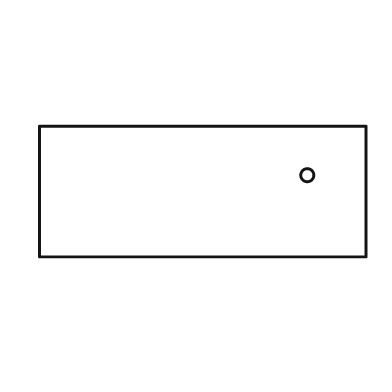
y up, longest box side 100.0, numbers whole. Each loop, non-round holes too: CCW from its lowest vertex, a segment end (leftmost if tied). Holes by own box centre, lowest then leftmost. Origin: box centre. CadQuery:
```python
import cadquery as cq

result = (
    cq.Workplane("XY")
    .moveTo(-50.0, -20.0)
    .lineTo(50.0, -20.0)
    .lineTo(50.0, 20.0)
    .lineTo(-50.0, 20.0)
    .close()
    .moveTo(32.0, 5.0)
    .circle(2.0)
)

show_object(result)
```